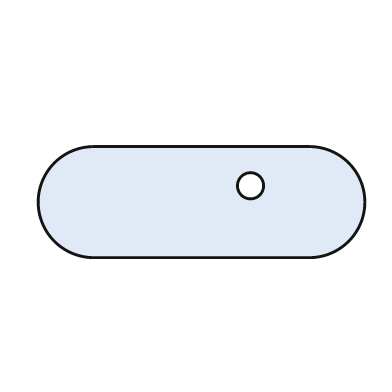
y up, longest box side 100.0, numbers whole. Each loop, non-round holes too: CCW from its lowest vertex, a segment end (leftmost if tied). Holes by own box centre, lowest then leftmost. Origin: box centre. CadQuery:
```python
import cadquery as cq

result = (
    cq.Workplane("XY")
    .moveTo(-33.0, -17.0)
    .lineTo(33.0, -17.0)
    .threePointArc((50.0, 0.0), (33.0, 17.0))
    .lineTo(-33.0, 17.0)
    .threePointArc((-50.0, 0.0), (-33.0, -17.0))
    .close()
    .moveTo(15.0, 5.0)
    .circle(4.0)
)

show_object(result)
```